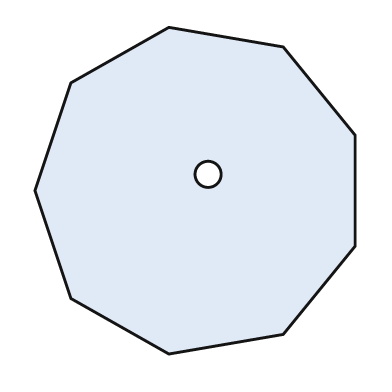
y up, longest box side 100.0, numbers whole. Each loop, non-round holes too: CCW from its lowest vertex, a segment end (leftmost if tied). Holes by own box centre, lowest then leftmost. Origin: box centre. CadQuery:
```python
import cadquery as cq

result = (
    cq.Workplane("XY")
    .moveTo(-8.0, -50.0)
    .lineTo(27.0, -44.0)
    .lineTo(49.0, -17.0)
    .lineTo(49.0, 17.0)
    .lineTo(27.0, 44.0)
    .lineTo(-8.0, 50.0)
    .lineTo(-38.0, 33.0)
    .lineTo(-49.0, 0.0)
    .lineTo(-38.0, -33.0)
    .close()
    .moveTo(4.0, 5.0)
    .circle(4.0)
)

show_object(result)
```